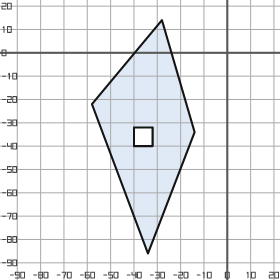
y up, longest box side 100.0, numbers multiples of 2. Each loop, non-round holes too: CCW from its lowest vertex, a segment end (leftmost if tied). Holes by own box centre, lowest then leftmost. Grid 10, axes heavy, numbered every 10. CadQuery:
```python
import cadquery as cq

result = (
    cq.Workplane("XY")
    .moveTo(-34.0, -86.0)
    .lineTo(-14.0, -34.0)
    .lineTo(-28.0, 14.0)
    .lineTo(-58.0, -22.0)
    .close()
    .moveTo(-40.0, -40.0)
    .lineTo(-32.0, -40.0)
    .lineTo(-32.0, -32.0)
    .lineTo(-40.0, -32.0)
    .close()
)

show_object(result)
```